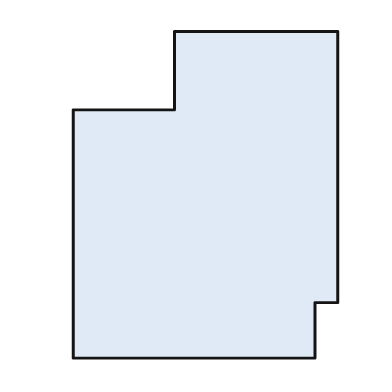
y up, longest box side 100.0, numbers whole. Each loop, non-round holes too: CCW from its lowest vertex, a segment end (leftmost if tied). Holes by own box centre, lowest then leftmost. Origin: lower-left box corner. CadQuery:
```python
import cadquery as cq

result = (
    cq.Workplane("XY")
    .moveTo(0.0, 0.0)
    .lineTo(74.0, 0.0)
    .lineTo(74.0, 17.0)
    .lineTo(81.0, 17.0)
    .lineTo(81.0, 100.0)
    .lineTo(31.0, 100.0)
    .lineTo(31.0, 76.0)
    .lineTo(0.0, 76.0)
    .close()
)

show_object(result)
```